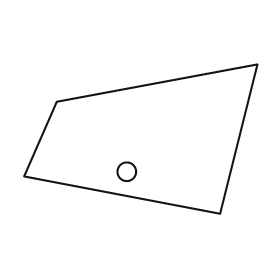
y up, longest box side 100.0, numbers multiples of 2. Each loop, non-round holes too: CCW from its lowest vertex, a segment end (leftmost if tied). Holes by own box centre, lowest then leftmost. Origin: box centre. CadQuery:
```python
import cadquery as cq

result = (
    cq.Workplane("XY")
    .moveTo(34.0, -32.0)
    .lineTo(50.0, 32.0)
    .lineTo(-36.0, 16.0)
    .lineTo(-50.0, -16.0)
    .close()
    .moveTo(-6.0, -14.0)
    .circle(4.0)
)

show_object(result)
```